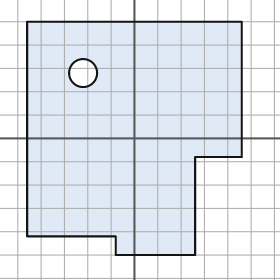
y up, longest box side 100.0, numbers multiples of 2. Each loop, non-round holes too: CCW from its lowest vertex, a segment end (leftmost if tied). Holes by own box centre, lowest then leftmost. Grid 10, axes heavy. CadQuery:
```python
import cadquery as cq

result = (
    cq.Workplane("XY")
    .moveTo(-8.0, -50.0)
    .lineTo(26.0, -50.0)
    .lineTo(26.0, -8.0)
    .lineTo(46.0, -8.0)
    .lineTo(46.0, 50.0)
    .lineTo(-46.0, 50.0)
    .lineTo(-46.0, -42.0)
    .lineTo(-8.0, -42.0)
    .close()
    .moveTo(-22.0, 28.0)
    .circle(6.0)
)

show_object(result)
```